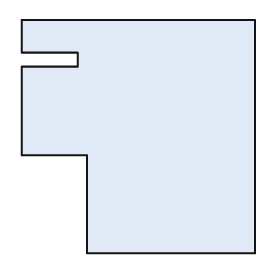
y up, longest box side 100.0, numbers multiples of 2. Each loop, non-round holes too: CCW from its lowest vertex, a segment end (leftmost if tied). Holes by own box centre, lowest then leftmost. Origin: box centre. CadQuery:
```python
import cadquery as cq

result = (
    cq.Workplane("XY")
    .moveTo(-22.0, -50.0)
    .lineTo(50.0, -50.0)
    .lineTo(50.0, 50.0)
    .lineTo(-50.0, 50.0)
    .lineTo(-50.0, 36.0)
    .lineTo(-26.0, 36.0)
    .lineTo(-26.0, 30.0)
    .lineTo(-50.0, 30.0)
    .lineTo(-50.0, -8.0)
    .lineTo(-22.0, -8.0)
    .close()
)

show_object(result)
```